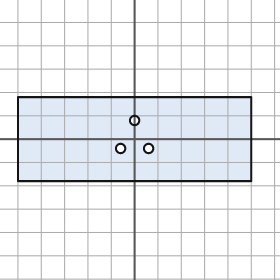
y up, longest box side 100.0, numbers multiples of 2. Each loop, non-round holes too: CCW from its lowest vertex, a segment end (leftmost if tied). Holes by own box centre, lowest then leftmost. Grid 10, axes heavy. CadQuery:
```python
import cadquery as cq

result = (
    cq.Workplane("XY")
    .moveTo(-50.0, -18.0)
    .lineTo(50.0, -18.0)
    .lineTo(50.0, 18.0)
    .lineTo(-50.0, 18.0)
    .close()
    .moveTo(-6.0, -4.0)
    .circle(2.0)
    .moveTo(6.0, -4.0)
    .circle(2.0)
    .moveTo(0.0, 8.0)
    .circle(2.0)
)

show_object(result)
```